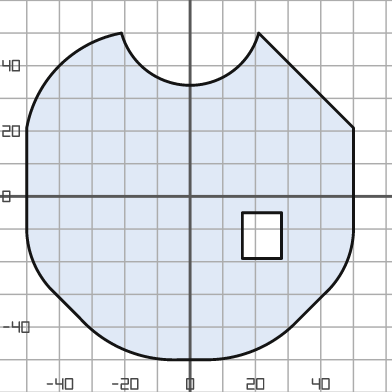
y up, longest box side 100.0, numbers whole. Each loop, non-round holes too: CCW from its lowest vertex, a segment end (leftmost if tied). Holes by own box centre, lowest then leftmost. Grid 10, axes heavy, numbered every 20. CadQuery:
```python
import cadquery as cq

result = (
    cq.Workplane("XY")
    .moveTo(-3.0, -50.0)
    .lineTo(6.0, -50.0)
    .threePointArc((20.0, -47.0), (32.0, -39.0))
    .lineTo(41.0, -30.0)
    .threePointArc((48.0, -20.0), (50.0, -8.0))
    .lineTo(50.0, 21.0)
    .lineTo(21.0, 50.0)
    .threePointArc((0.0, 34.0), (-21.0, 50.0))
    .threePointArc((-40.0, 40.0), (-50.0, 21.0))
    .lineTo(-50.0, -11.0)
    .threePointArc((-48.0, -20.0), (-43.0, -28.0))
    .lineTo(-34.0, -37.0)
    .threePointArc((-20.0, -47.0), (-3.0, -50.0))
    .close()
    .moveTo(16.0, -19.0)
    .lineTo(28.0, -19.0)
    .lineTo(28.0, -5.0)
    .lineTo(16.0, -5.0)
    .close()
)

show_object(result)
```